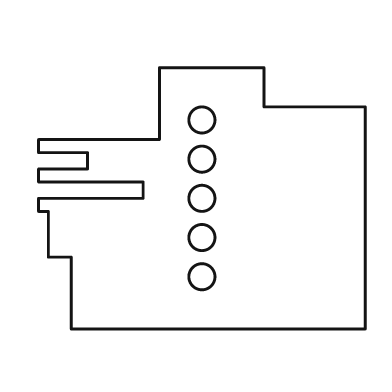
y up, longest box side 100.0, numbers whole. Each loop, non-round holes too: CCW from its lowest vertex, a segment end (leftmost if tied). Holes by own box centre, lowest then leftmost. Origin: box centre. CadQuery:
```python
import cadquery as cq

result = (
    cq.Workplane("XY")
    .moveTo(-40.0, -40.0)
    .lineTo(50.0, -40.0)
    .lineTo(50.0, 28.0)
    .lineTo(19.0, 28.0)
    .lineTo(19.0, 40.0)
    .lineTo(-13.0, 40.0)
    .lineTo(-13.0, 18.0)
    .lineTo(-50.0, 18.0)
    .lineTo(-50.0, 14.0)
    .lineTo(-35.0, 14.0)
    .lineTo(-35.0, 9.0)
    .lineTo(-50.0, 9.0)
    .lineTo(-50.0, 5.0)
    .lineTo(-18.0, 5.0)
    .lineTo(-18.0, 0.0)
    .lineTo(-50.0, 0.0)
    .lineTo(-50.0, -4.0)
    .lineTo(-47.0, -4.0)
    .lineTo(-47.0, -18.0)
    .lineTo(-40.0, -18.0)
    .close()
    .moveTo(0.0, -24.0)
    .circle(4.0)
    .moveTo(0.0, -12.0)
    .circle(4.0)
    .moveTo(0.0, 0.0)
    .circle(4.0)
    .moveTo(0.0, 12.0)
    .circle(4.0)
    .moveTo(0.0, 24.0)
    .circle(4.0)
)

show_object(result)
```